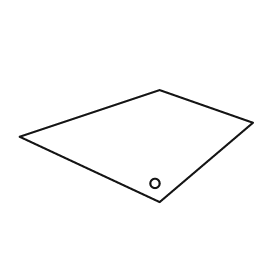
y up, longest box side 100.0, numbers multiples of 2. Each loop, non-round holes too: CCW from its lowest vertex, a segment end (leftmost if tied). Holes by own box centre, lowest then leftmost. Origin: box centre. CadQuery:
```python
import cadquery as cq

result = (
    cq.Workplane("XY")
    .moveTo(10.0, -24.0)
    .lineTo(50.0, 10.0)
    .lineTo(10.0, 24.0)
    .lineTo(-50.0, 4.0)
    .close()
    .moveTo(8.0, -16.0)
    .circle(2.0)
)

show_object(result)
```